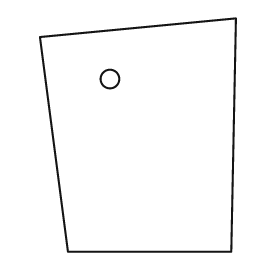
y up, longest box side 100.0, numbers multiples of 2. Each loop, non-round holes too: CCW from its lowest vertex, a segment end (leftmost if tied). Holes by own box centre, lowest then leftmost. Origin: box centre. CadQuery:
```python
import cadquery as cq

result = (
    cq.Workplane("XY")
    .moveTo(-30.0, -50.0)
    .lineTo(40.0, -50.0)
    .lineTo(42.0, 50.0)
    .lineTo(-42.0, 42.0)
    .close()
    .moveTo(-12.0, 24.0)
    .circle(4.0)
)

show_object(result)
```